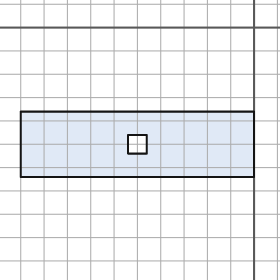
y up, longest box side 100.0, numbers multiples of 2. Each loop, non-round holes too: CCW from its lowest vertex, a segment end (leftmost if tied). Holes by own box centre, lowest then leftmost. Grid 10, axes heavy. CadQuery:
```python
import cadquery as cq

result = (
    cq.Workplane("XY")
    .moveTo(-100.0, -64.0)
    .lineTo(0.0, -64.0)
    .lineTo(0.0, -36.0)
    .lineTo(-100.0, -36.0)
    .close()
    .moveTo(-54.0, -54.0)
    .lineTo(-46.0, -54.0)
    .lineTo(-46.0, -46.0)
    .lineTo(-54.0, -46.0)
    .close()
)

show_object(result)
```